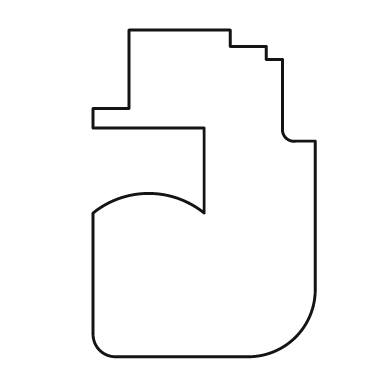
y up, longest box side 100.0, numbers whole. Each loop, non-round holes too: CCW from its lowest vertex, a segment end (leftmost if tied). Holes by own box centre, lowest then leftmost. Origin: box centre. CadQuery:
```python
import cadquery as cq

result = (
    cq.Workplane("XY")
    .moveTo(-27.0, -50.0)
    .lineTo(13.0, -50.0)
    .threePointArc((28.0, -44.0), (34.0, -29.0))
    .lineTo(34.0, 16.0)
    .lineTo(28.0, 16.0)
    .threePointArc((25.0, 17.0), (24.0, 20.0))
    .lineTo(24.0, 41.0)
    .lineTo(19.0, 41.0)
    .lineTo(19.0, 45.0)
    .lineTo(8.0, 45.0)
    .lineTo(8.0, 50.0)
    .lineTo(-23.0, 50.0)
    .lineTo(-23.0, 26.0)
    .lineTo(-34.0, 26.0)
    .lineTo(-34.0, 20.0)
    .lineTo(0.0, 20.0)
    .lineTo(0.0, -6.0)
    .threePointArc((-17.0, 0.0), (-34.0, -6.0))
    .lineTo(-34.0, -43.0)
    .threePointArc((-32.0, -48.0), (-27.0, -50.0))
    .close()
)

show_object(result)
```